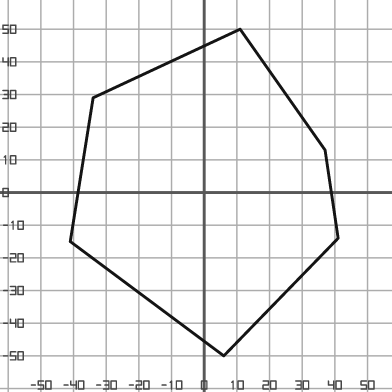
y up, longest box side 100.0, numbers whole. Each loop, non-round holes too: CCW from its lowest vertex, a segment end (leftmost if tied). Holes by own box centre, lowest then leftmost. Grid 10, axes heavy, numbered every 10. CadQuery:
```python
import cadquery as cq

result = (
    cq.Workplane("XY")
    .moveTo(6.0, -50.0)
    .lineTo(41.0, -14.0)
    .lineTo(37.0, 13.0)
    .lineTo(11.0, 50.0)
    .lineTo(-34.0, 29.0)
    .lineTo(-41.0, -15.0)
    .close()
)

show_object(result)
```